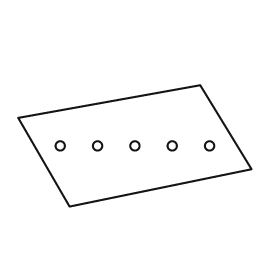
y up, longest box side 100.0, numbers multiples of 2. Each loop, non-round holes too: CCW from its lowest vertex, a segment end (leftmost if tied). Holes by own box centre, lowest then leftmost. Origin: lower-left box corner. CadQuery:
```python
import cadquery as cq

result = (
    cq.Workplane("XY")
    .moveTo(22.0, 0.0)
    .lineTo(100.0, 16.0)
    .lineTo(78.0, 52.0)
    .lineTo(0.0, 38.0)
    .close()
    .moveTo(18.0, 26.0)
    .circle(2.0)
    .moveTo(34.0, 26.0)
    .circle(2.0)
    .moveTo(50.0, 26.0)
    .circle(2.0)
    .moveTo(66.0, 26.0)
    .circle(2.0)
    .moveTo(82.0, 26.0)
    .circle(2.0)
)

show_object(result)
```